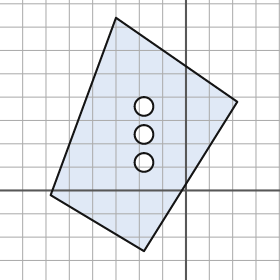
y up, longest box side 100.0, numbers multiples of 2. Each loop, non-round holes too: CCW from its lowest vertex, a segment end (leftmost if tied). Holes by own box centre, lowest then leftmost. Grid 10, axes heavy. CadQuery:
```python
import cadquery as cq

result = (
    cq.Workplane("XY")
    .moveTo(-18.0, -26.0)
    .lineTo(22.0, 38.0)
    .lineTo(-30.0, 74.0)
    .lineTo(-58.0, -2.0)
    .close()
    .moveTo(-18.0, 12.0)
    .circle(4.0)
    .moveTo(-18.0, 24.0)
    .circle(4.0)
    .moveTo(-18.0, 36.0)
    .circle(4.0)
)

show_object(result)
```